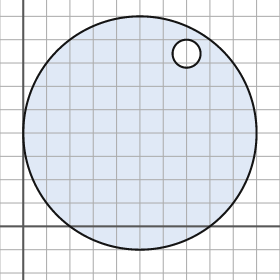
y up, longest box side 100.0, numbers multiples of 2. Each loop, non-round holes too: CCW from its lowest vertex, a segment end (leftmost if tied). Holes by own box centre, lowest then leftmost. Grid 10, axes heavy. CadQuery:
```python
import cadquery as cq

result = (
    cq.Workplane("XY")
    .moveTo(50.0, 40.0)
    .circle(50.0)
    .moveTo(70.0, 74.0)
    .circle(6.0)
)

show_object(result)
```